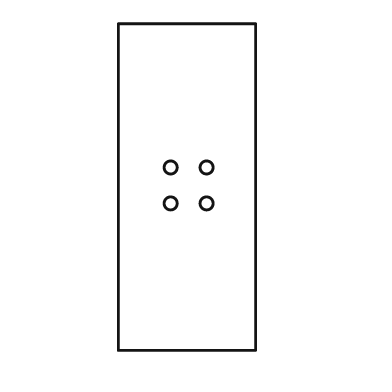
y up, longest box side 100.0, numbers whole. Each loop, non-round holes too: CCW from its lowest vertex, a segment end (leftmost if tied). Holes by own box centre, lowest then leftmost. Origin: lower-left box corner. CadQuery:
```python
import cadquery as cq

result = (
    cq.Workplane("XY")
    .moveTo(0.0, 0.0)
    .lineTo(42.0, 0.0)
    .lineTo(42.0, 100.0)
    .lineTo(0.0, 100.0)
    .close()
    .moveTo(16.0, 45.0)
    .circle(2.0)
    .moveTo(27.0, 45.0)
    .circle(2.0)
    .moveTo(16.0, 56.0)
    .circle(2.0)
    .moveTo(27.0, 56.0)
    .circle(2.0)
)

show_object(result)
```